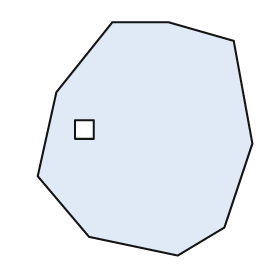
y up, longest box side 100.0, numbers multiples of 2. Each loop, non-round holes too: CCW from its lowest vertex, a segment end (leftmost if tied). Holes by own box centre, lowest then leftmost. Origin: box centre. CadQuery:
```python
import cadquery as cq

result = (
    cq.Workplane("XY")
    .moveTo(14.0, -50.0)
    .lineTo(34.0, -38.0)
    .lineTo(46.0, -2.0)
    .lineTo(38.0, 42.0)
    .lineTo(10.0, 50.0)
    .lineTo(-14.0, 50.0)
    .lineTo(-38.0, 20.0)
    .lineTo(-46.0, -16.0)
    .lineTo(-24.0, -42.0)
    .close()
    .moveTo(-30.0, 0.0)
    .lineTo(-22.0, 0.0)
    .lineTo(-22.0, 8.0)
    .lineTo(-30.0, 8.0)
    .close()
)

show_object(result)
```